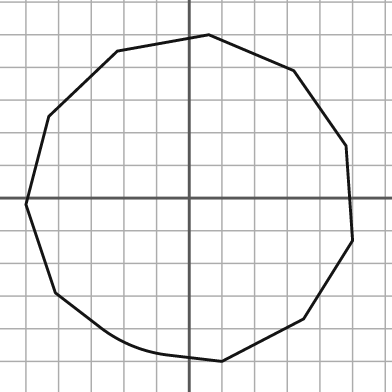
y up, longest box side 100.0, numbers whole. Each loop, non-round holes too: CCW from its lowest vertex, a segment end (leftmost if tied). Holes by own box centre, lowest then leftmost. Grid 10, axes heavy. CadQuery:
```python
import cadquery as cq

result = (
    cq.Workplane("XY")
    .moveTo(10.0, -50.0)
    .lineTo(35.0, -37.0)
    .lineTo(50.0, -13.0)
    .lineTo(48.0, 16.0)
    .lineTo(32.0, 39.0)
    .lineTo(6.0, 50.0)
    .lineTo(-22.0, 45.0)
    .lineTo(-43.0, 25.0)
    .lineTo(-50.0, -2.0)
    .lineTo(-41.0, -29.0)
    .lineTo(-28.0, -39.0)
    .threePointArc((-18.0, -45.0), (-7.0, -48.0))
    .close()
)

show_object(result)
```